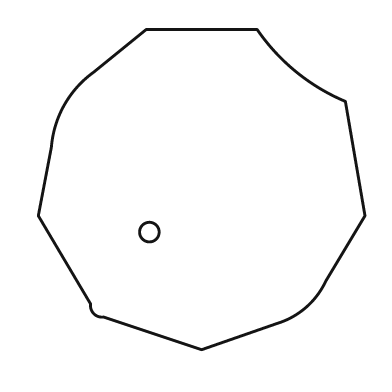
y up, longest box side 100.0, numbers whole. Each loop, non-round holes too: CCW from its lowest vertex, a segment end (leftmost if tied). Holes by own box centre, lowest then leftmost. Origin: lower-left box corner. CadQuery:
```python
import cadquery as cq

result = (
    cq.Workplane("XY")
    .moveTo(50.0, 0.0)
    .lineTo(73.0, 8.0)
    .threePointArc((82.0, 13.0), (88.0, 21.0))
    .lineTo(100.0, 41.0)
    .lineTo(94.0, 76.0)
    .threePointArc((79.0, 85.0), (67.0, 98.0))
    .lineTo(33.0, 98.0)
    .lineTo(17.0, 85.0)
    .threePointArc((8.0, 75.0), (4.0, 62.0))
    .lineTo(0.0, 41.0)
    .lineTo(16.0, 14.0)
    .threePointArc((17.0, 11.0), (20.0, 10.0))
    .close()
    .moveTo(34.0, 36.0)
    .circle(3.0)
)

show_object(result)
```